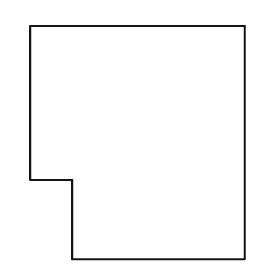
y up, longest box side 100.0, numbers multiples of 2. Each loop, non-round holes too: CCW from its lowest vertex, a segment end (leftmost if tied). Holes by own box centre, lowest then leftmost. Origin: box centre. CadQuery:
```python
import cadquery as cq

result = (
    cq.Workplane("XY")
    .moveTo(-28.0, -50.0)
    .lineTo(46.0, -50.0)
    .lineTo(46.0, 50.0)
    .lineTo(-46.0, 50.0)
    .lineTo(-46.0, -16.0)
    .lineTo(-28.0, -16.0)
    .close()
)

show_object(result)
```